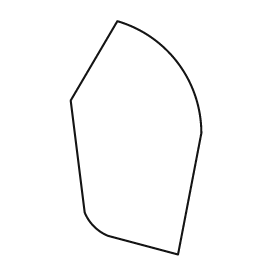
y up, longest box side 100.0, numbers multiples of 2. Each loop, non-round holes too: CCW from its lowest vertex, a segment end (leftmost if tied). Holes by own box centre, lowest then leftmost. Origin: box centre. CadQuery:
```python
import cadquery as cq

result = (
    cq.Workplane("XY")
    .moveTo(18.0, -50.0)
    .lineTo(28.0, 2.0)
    .threePointArc((18.0, 32.0), (-8.0, 50.0))
    .lineTo(-28.0, 16.0)
    .lineTo(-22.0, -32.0)
    .threePointArc((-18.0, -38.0), (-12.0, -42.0))
    .close()
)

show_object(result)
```